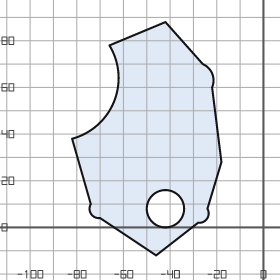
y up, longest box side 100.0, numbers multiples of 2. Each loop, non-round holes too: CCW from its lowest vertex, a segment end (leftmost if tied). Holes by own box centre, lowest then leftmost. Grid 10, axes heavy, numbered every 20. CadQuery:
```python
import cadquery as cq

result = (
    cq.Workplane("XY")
    .moveTo(-46.0, -12.0)
    .lineTo(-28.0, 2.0)
    .threePointArc((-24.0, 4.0), (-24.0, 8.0))
    .lineTo(-18.0, 28.0)
    .lineTo(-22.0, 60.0)
    .threePointArc((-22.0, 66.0), (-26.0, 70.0))
    .lineTo(-42.0, 88.0)
    .lineTo(-66.0, 78.0)
    .threePointArc((-64.0, 54.0), (-82.0, 38.0))
    .lineTo(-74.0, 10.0)
    .threePointArc((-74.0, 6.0), (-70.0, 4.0))
    .close()
    .moveTo(-42.0, 8.0)
    .circle(8.0)
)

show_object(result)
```